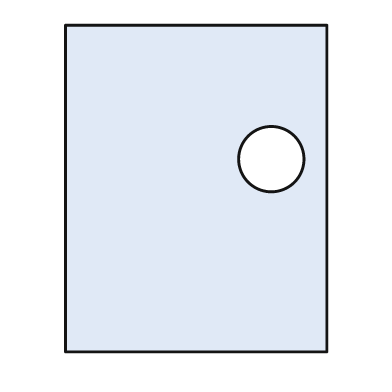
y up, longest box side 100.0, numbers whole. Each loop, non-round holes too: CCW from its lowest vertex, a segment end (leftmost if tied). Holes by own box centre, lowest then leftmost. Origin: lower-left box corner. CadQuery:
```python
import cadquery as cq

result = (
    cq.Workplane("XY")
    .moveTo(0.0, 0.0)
    .lineTo(80.0, 0.0)
    .lineTo(80.0, 100.0)
    .lineTo(0.0, 100.0)
    .close()
    .moveTo(63.0, 59.0)
    .circle(10.0)
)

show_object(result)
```